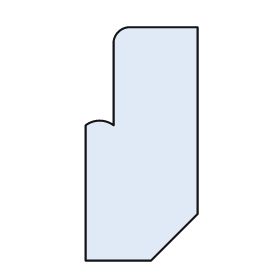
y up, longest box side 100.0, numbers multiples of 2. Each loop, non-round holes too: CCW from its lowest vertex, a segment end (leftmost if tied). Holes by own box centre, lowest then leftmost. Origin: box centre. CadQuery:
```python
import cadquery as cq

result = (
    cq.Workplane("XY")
    .moveTo(-24.0, -50.0)
    .lineTo(4.0, -50.0)
    .lineTo(24.0, -30.0)
    .lineTo(24.0, 50.0)
    .lineTo(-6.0, 50.0)
    .threePointArc((-10.0, 48.0), (-12.0, 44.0))
    .lineTo(-12.0, 8.0)
    .threePointArc((-18.0, 10.0), (-24.0, 8.0))
    .close()
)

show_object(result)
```